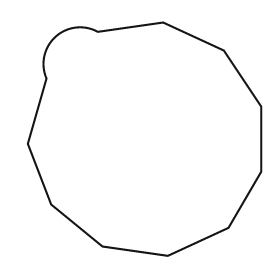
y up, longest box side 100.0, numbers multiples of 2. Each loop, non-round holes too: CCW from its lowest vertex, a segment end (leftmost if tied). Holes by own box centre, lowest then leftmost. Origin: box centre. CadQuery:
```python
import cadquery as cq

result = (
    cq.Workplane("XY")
    .moveTo(10.0, -50.0)
    .lineTo(36.0, -38.0)
    .lineTo(50.0, -14.0)
    .lineTo(50.0, 14.0)
    .lineTo(34.0, 38.0)
    .lineTo(8.0, 50.0)
    .lineTo(-20.0, 46.0)
    .threePointArc((-38.0, 44.0), (-42.0, 26.0))
    .lineTo(-50.0, -2.0)
    .lineTo(-40.0, -28.0)
    .lineTo(-18.0, -46.0)
    .close()
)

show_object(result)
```